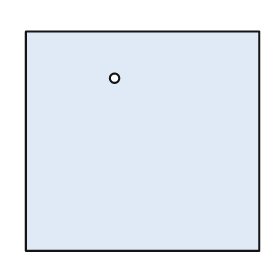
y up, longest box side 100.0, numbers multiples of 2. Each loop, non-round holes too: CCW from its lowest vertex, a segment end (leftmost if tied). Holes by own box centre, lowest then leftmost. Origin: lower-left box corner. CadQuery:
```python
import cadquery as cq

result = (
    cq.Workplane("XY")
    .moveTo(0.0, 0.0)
    .lineTo(100.0, 0.0)
    .lineTo(100.0, 94.0)
    .lineTo(0.0, 94.0)
    .close()
    .moveTo(38.0, 74.0)
    .circle(2.0)
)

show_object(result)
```